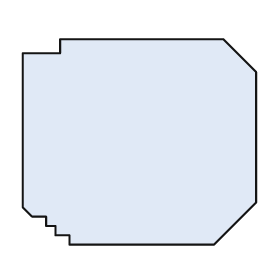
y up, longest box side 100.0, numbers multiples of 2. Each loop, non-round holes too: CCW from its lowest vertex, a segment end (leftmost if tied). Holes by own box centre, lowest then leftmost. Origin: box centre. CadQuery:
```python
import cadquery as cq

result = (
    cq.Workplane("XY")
    .moveTo(-30.0, -44.0)
    .lineTo(32.0, -44.0)
    .lineTo(50.0, -26.0)
    .lineTo(50.0, 30.0)
    .lineTo(36.0, 44.0)
    .lineTo(-34.0, 44.0)
    .lineTo(-34.0, 38.0)
    .lineTo(-50.0, 38.0)
    .lineTo(-50.0, -28.0)
    .lineTo(-46.0, -32.0)
    .lineTo(-40.0, -32.0)
    .lineTo(-40.0, -36.0)
    .lineTo(-36.0, -36.0)
    .lineTo(-36.0, -40.0)
    .lineTo(-30.0, -40.0)
    .close()
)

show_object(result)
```